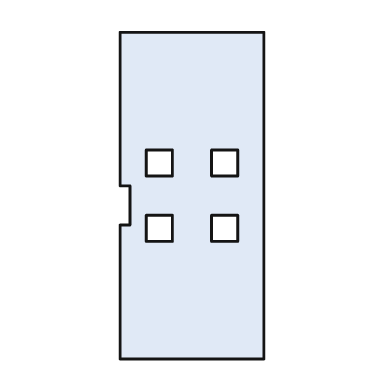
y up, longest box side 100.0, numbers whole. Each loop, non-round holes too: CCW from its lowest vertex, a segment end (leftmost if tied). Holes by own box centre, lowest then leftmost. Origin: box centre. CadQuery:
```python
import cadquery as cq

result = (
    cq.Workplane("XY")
    .moveTo(-22.0, -50.0)
    .lineTo(22.0, -50.0)
    .lineTo(22.0, 50.0)
    .lineTo(-22.0, 50.0)
    .lineTo(-22.0, 3.0)
    .lineTo(-19.0, 3.0)
    .lineTo(-19.0, -9.0)
    .lineTo(-22.0, -9.0)
    .close()
    .moveTo(-14.0, -14.0)
    .lineTo(-6.0, -14.0)
    .lineTo(-6.0, -6.0)
    .lineTo(-14.0, -6.0)
    .close()
    .moveTo(6.0, -14.0)
    .lineTo(14.0, -14.0)
    .lineTo(14.0, -6.0)
    .lineTo(6.0, -6.0)
    .close()
    .moveTo(-14.0, 6.0)
    .lineTo(-6.0, 6.0)
    .lineTo(-6.0, 14.0)
    .lineTo(-14.0, 14.0)
    .close()
    .moveTo(6.0, 6.0)
    .lineTo(14.0, 6.0)
    .lineTo(14.0, 14.0)
    .lineTo(6.0, 14.0)
    .close()
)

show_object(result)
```